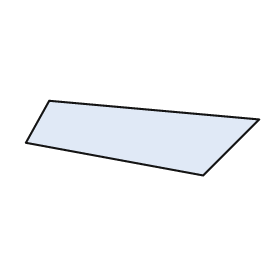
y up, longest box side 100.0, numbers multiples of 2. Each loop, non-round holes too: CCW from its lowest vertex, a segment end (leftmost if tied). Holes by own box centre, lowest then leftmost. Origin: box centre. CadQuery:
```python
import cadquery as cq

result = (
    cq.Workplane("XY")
    .moveTo(26.0, -16.0)
    .lineTo(50.0, 8.0)
    .lineTo(-40.0, 16.0)
    .lineTo(-50.0, -2.0)
    .close()
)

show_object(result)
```